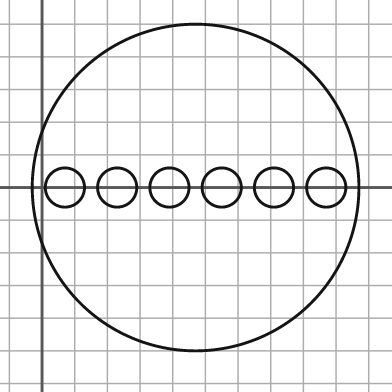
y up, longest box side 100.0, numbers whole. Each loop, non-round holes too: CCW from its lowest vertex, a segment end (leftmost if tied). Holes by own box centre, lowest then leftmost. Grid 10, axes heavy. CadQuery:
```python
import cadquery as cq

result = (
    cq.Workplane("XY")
    .moveTo(47.0, 0.0)
    .circle(50.0)
    .moveTo(7.0, 0.0)
    .circle(6.0)
    .moveTo(23.0, 0.0)
    .circle(6.0)
    .moveTo(39.0, 0.0)
    .circle(6.0)
    .moveTo(55.0, 0.0)
    .circle(6.0)
    .moveTo(71.0, 0.0)
    .circle(6.0)
    .moveTo(87.0, 0.0)
    .circle(6.0)
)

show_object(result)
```